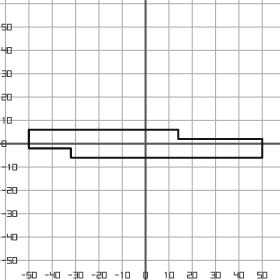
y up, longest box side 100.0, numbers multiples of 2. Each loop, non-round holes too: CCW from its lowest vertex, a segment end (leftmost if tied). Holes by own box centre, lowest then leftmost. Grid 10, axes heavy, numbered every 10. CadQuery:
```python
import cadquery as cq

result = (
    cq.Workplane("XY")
    .moveTo(-32.0, -6.0)
    .lineTo(50.0, -6.0)
    .lineTo(50.0, 2.0)
    .lineTo(14.0, 2.0)
    .lineTo(14.0, 6.0)
    .lineTo(-50.0, 6.0)
    .lineTo(-50.0, -2.0)
    .lineTo(-32.0, -2.0)
    .close()
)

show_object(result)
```